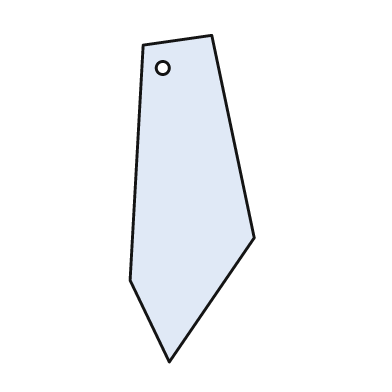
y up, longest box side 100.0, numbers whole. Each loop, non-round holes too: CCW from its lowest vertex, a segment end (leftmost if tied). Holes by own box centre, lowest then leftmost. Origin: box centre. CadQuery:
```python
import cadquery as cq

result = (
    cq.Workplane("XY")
    .moveTo(-7.0, -50.0)
    .lineTo(19.0, -12.0)
    .lineTo(6.0, 50.0)
    .lineTo(-15.0, 47.0)
    .lineTo(-19.0, -25.0)
    .close()
    .moveTo(-9.0, 40.0)
    .circle(2.0)
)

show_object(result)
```